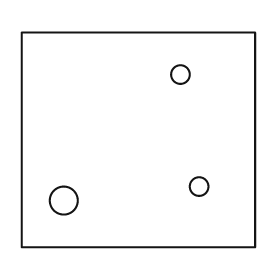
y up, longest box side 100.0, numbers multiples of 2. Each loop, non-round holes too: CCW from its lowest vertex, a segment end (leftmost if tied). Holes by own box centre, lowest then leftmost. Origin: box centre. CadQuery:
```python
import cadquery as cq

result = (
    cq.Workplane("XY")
    .moveTo(-50.0, -46.0)
    .lineTo(50.0, -46.0)
    .lineTo(50.0, 46.0)
    .lineTo(-50.0, 46.0)
    .close()
    .moveTo(-32.0, -26.0)
    .circle(6.0)
    .moveTo(26.0, -20.0)
    .circle(4.0)
    .moveTo(18.0, 28.0)
    .circle(4.0)
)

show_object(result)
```